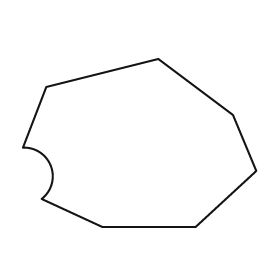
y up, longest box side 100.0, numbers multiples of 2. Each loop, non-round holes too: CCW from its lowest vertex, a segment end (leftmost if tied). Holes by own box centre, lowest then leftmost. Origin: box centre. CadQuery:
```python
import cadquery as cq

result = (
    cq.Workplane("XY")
    .moveTo(-16.0, -36.0)
    .lineTo(24.0, -36.0)
    .lineTo(50.0, -12.0)
    .lineTo(40.0, 12.0)
    .lineTo(8.0, 36.0)
    .lineTo(-40.0, 24.0)
    .lineTo(-50.0, -2.0)
    .threePointArc((-38.0, -10.0), (-42.0, -24.0))
    .close()
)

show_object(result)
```